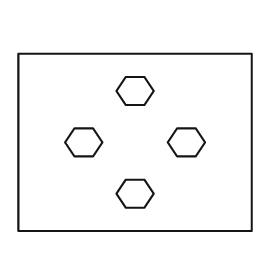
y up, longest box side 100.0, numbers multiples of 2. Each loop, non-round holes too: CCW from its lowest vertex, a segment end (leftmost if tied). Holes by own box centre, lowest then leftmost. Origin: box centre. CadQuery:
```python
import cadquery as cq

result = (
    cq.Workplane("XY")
    .moveTo(-50.0, -38.0)
    .lineTo(50.0, -38.0)
    .lineTo(50.0, 38.0)
    .lineTo(-50.0, 38.0)
    .close()
    .moveTo(-4.0, -28.0)
    .lineTo(4.0, -28.0)
    .lineTo(8.0, -22.0)
    .lineTo(4.0, -16.0)
    .lineTo(-4.0, -16.0)
    .lineTo(-8.0, -22.0)
    .close()
    .moveTo(-26.0, -6.0)
    .lineTo(-18.0, -6.0)
    .lineTo(-14.0, 0.0)
    .lineTo(-18.0, 6.0)
    .lineTo(-26.0, 6.0)
    .lineTo(-30.0, 0.0)
    .close()
    .moveTo(18.0, -6.0)
    .lineTo(26.0, -6.0)
    .lineTo(30.0, 0.0)
    .lineTo(26.0, 6.0)
    .lineTo(18.0, 6.0)
    .lineTo(14.0, 0.0)
    .close()
    .moveTo(-4.0, 16.0)
    .lineTo(4.0, 16.0)
    .lineTo(8.0, 22.0)
    .lineTo(4.0, 28.0)
    .lineTo(-4.0, 28.0)
    .lineTo(-8.0, 22.0)
    .close()
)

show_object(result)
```